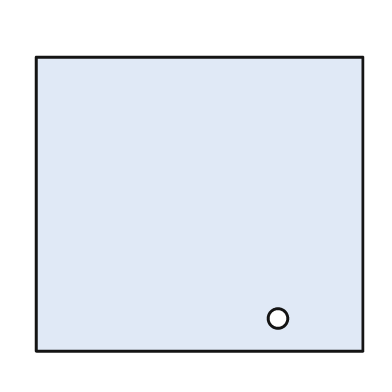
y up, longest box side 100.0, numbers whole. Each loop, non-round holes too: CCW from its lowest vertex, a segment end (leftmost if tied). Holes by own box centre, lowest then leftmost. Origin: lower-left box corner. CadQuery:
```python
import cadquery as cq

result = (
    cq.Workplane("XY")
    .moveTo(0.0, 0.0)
    .lineTo(100.0, 0.0)
    .lineTo(100.0, 90.0)
    .lineTo(0.0, 90.0)
    .close()
    .moveTo(74.0, 10.0)
    .circle(3.0)
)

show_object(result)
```